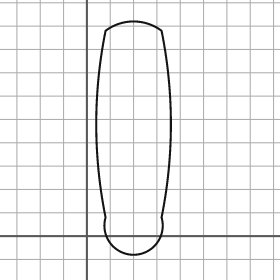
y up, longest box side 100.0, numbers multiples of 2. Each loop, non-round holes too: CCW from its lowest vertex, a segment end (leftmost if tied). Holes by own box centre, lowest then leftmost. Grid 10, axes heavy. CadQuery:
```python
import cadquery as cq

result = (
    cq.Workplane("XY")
    .moveTo(8.0, 8.0)
    .threePointArc((20.0, -8.0), (32.0, 8.0))
    .threePointArc((36.0, 48.0), (32.0, 88.0))
    .threePointArc((20.0, 92.0), (8.0, 88.0))
    .threePointArc((4.0, 48.0), (8.0, 8.0))
    .close()
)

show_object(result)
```